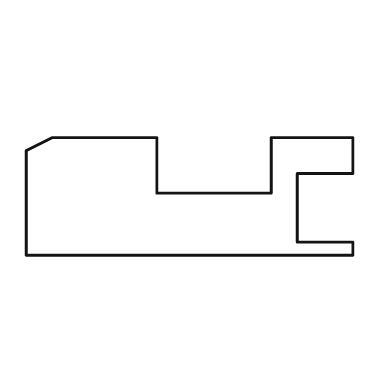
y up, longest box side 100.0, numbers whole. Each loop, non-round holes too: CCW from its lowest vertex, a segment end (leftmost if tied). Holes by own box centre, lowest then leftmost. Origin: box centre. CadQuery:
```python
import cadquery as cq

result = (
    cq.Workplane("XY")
    .moveTo(-50.0, -18.0)
    .lineTo(50.0, -18.0)
    .lineTo(50.0, -14.0)
    .lineTo(33.0, -14.0)
    .lineTo(33.0, 7.0)
    .lineTo(50.0, 7.0)
    .lineTo(50.0, 18.0)
    .lineTo(25.0, 18.0)
    .lineTo(25.0, 1.0)
    .lineTo(-10.0, 1.0)
    .lineTo(-10.0, 18.0)
    .lineTo(-42.0, 18.0)
    .lineTo(-50.0, 14.0)
    .close()
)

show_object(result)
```